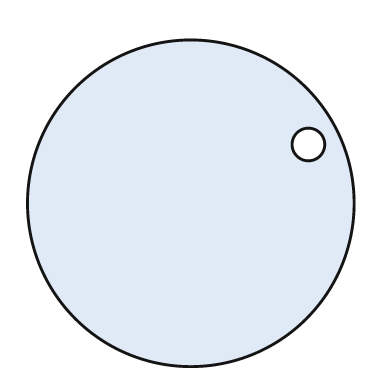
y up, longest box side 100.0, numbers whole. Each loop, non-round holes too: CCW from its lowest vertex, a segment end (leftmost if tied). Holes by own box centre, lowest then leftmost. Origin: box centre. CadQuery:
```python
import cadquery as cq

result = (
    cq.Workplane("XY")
    .moveTo(0.0, 0.0)
    .circle(50.0)
    .moveTo(36.0, 18.0)
    .circle(5.0)
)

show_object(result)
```